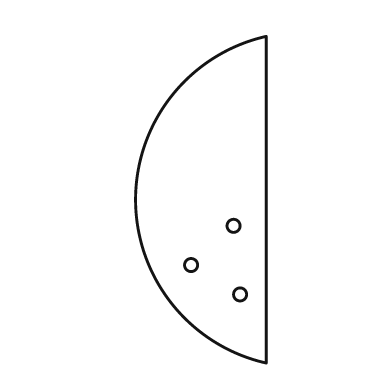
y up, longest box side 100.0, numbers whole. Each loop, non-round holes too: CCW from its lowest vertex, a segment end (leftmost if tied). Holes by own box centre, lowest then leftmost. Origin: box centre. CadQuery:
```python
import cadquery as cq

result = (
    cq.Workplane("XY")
    .moveTo(20.0, -50.0)
    .lineTo(20.0, 50.0)
    .threePointArc((-20.0, 0.0), (20.0, -50.0))
    .close()
    .moveTo(12.0, -29.0)
    .circle(2.0)
    .moveTo(-3.0, -20.0)
    .circle(2.0)
    .moveTo(10.0, -8.0)
    .circle(2.0)
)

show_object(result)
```